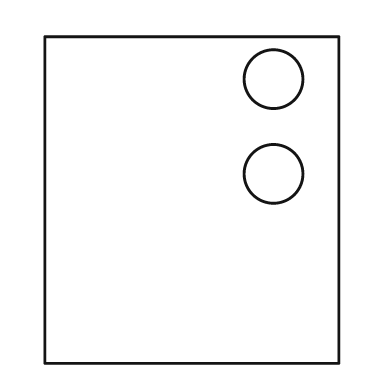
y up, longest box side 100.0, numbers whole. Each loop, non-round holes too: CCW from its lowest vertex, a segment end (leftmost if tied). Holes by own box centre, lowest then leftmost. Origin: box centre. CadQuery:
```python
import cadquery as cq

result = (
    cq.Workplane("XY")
    .moveTo(-45.0, -50.0)
    .lineTo(45.0, -50.0)
    .lineTo(45.0, 50.0)
    .lineTo(-45.0, 50.0)
    .close()
    .moveTo(25.0, 8.0)
    .circle(9.0)
    .moveTo(25.0, 37.0)
    .circle(9.0)
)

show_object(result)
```